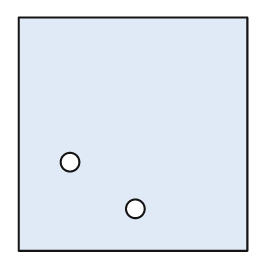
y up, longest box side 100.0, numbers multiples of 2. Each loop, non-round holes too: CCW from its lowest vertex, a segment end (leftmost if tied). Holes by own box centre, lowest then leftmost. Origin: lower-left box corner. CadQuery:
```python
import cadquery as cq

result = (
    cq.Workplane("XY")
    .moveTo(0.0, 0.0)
    .lineTo(98.0, 0.0)
    .lineTo(98.0, 100.0)
    .lineTo(0.0, 100.0)
    .close()
    .moveTo(50.0, 18.0)
    .circle(4.0)
    .moveTo(22.0, 38.0)
    .circle(4.0)
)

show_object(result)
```